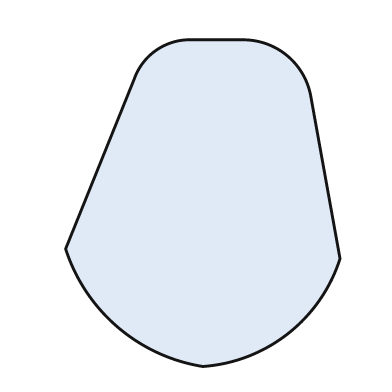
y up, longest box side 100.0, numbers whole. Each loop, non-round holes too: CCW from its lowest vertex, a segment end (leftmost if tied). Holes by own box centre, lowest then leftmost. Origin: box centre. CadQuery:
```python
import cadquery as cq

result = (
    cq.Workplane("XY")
    .moveTo(0.0, -50.0)
    .threePointArc((26.0, -40.0), (42.0, -17.0))
    .lineTo(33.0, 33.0)
    .threePointArc((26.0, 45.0), (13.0, 50.0))
    .lineTo(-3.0, 50.0)
    .threePointArc((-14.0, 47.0), (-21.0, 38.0))
    .lineTo(-42.0, -14.0)
    .threePointArc((-26.0, -38.0), (0.0, -50.0))
    .close()
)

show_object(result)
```